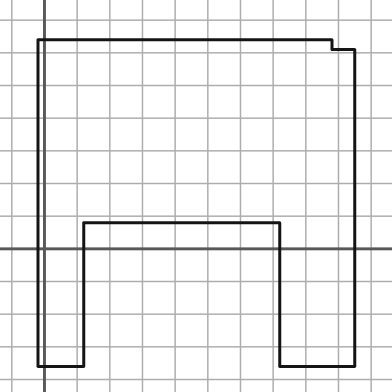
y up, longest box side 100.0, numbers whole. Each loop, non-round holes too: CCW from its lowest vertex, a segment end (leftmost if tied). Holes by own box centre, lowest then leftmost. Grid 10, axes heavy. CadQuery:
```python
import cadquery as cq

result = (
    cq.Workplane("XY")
    .moveTo(-2.0, -36.0)
    .lineTo(12.0, -36.0)
    .lineTo(12.0, 8.0)
    .lineTo(72.0, 8.0)
    .lineTo(72.0, -36.0)
    .lineTo(95.0, -36.0)
    .lineTo(95.0, 61.0)
    .lineTo(88.0, 61.0)
    .lineTo(88.0, 64.0)
    .lineTo(-2.0, 64.0)
    .close()
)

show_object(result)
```